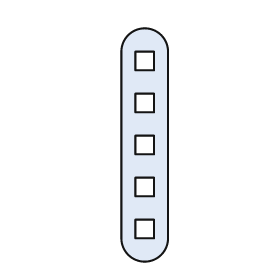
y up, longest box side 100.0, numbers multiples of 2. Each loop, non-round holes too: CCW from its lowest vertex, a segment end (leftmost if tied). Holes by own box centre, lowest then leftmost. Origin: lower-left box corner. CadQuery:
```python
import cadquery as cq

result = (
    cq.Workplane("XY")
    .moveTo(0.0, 10.0)
    .threePointArc((10.0, 0.0), (20.0, 10.0))
    .lineTo(20.0, 90.0)
    .threePointArc((10.0, 100.0), (0.0, 90.0))
    .close()
    .moveTo(6.0, 10.0)
    .lineTo(14.0, 10.0)
    .lineTo(14.0, 18.0)
    .lineTo(6.0, 18.0)
    .close()
    .moveTo(6.0, 28.0)
    .lineTo(14.0, 28.0)
    .lineTo(14.0, 36.0)
    .lineTo(6.0, 36.0)
    .close()
    .moveTo(6.0, 46.0)
    .lineTo(14.0, 46.0)
    .lineTo(14.0, 54.0)
    .lineTo(6.0, 54.0)
    .close()
    .moveTo(6.0, 64.0)
    .lineTo(14.0, 64.0)
    .lineTo(14.0, 72.0)
    .lineTo(6.0, 72.0)
    .close()
    .moveTo(6.0, 82.0)
    .lineTo(14.0, 82.0)
    .lineTo(14.0, 90.0)
    .lineTo(6.0, 90.0)
    .close()
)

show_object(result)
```